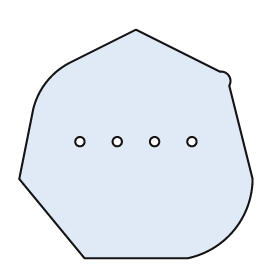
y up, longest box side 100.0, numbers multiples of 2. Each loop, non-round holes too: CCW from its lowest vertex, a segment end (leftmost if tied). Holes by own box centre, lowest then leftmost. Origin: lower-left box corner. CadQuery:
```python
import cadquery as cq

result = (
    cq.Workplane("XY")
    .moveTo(28.0, 0.0)
    .lineTo(72.0, 0.0)
    .threePointArc((92.0, 12.0), (100.0, 34.0))
    .lineTo(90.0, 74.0)
    .threePointArc((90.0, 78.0), (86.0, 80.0))
    .lineTo(50.0, 98.0)
    .lineTo(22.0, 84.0)
    .threePointArc((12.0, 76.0), (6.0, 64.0))
    .lineTo(0.0, 34.0)
    .close()
    .moveTo(26.0, 50.0)
    .circle(2.0)
    .moveTo(42.0, 50.0)
    .circle(2.0)
    .moveTo(58.0, 50.0)
    .circle(2.0)
    .moveTo(74.0, 50.0)
    .circle(2.0)
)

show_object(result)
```